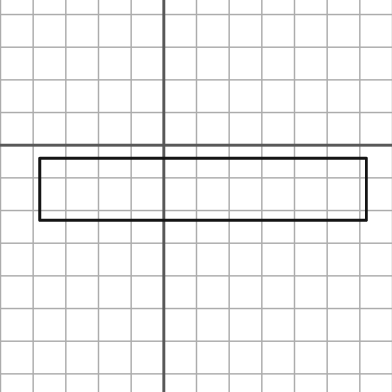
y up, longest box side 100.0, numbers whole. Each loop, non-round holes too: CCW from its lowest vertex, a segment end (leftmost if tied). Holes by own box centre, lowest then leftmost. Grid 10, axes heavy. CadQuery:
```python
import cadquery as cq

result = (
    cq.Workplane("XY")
    .moveTo(-38.0, -23.0)
    .lineTo(62.0, -23.0)
    .lineTo(62.0, -4.0)
    .lineTo(-38.0, -4.0)
    .close()
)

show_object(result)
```